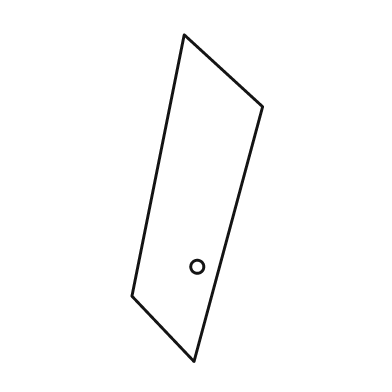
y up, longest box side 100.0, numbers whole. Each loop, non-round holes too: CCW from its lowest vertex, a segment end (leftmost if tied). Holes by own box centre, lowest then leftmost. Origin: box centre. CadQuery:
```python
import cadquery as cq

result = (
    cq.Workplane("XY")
    .moveTo(-1.0, -50.0)
    .lineTo(20.0, 28.0)
    .lineTo(-4.0, 50.0)
    .lineTo(-20.0, -30.0)
    .close()
    .moveTo(0.0, -21.0)
    .circle(2.0)
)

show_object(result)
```